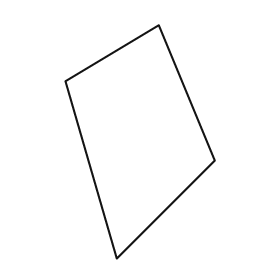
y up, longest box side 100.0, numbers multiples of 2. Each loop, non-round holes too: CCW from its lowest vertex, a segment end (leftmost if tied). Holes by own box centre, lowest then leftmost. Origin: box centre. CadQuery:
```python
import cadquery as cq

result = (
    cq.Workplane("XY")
    .moveTo(-10.0, -50.0)
    .lineTo(32.0, -8.0)
    .lineTo(8.0, 50.0)
    .lineTo(-32.0, 26.0)
    .close()
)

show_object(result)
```